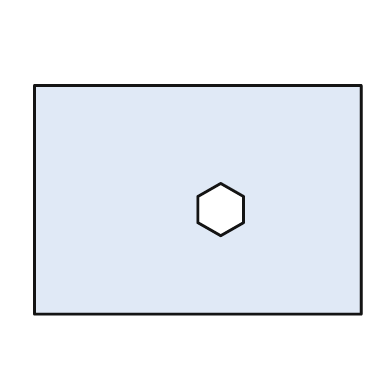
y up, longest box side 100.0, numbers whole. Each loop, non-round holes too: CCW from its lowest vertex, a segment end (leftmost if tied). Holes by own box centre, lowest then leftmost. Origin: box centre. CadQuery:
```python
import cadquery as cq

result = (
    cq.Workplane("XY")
    .moveTo(-50.0, -35.0)
    .lineTo(50.0, -35.0)
    .lineTo(50.0, 35.0)
    .lineTo(-50.0, 35.0)
    .close()
    .moveTo(7.0, -11.0)
    .lineTo(14.0, -7.0)
    .lineTo(14.0, 1.0)
    .lineTo(7.0, 5.0)
    .lineTo(0.0, 1.0)
    .lineTo(0.0, -7.0)
    .close()
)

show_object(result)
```